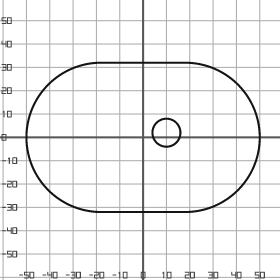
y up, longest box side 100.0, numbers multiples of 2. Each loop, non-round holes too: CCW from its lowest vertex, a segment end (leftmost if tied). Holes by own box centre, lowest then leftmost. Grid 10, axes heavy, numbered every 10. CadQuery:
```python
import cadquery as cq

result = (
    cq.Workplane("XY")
    .moveTo(-18.0, -32.0)
    .lineTo(18.0, -32.0)
    .threePointArc((50.0, 0.0), (18.0, 32.0))
    .lineTo(-18.0, 32.0)
    .threePointArc((-50.0, 0.0), (-18.0, -32.0))
    .close()
    .moveTo(10.0, 2.0)
    .circle(6.0)
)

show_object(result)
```